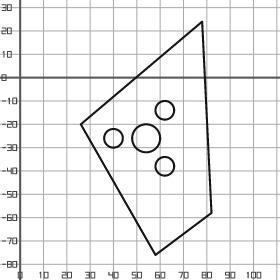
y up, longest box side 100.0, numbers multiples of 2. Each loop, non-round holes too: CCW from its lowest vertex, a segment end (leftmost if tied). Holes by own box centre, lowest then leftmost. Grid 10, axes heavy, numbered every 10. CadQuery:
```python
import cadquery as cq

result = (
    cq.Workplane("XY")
    .moveTo(58.0, -76.0)
    .lineTo(82.0, -58.0)
    .lineTo(78.0, 24.0)
    .lineTo(26.0, -20.0)
    .close()
    .moveTo(62.0, -38.0)
    .circle(4.0)
    .moveTo(40.0, -26.0)
    .circle(4.0)
    .moveTo(54.0, -26.0)
    .circle(6.0)
    .moveTo(62.0, -14.0)
    .circle(4.0)
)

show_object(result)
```